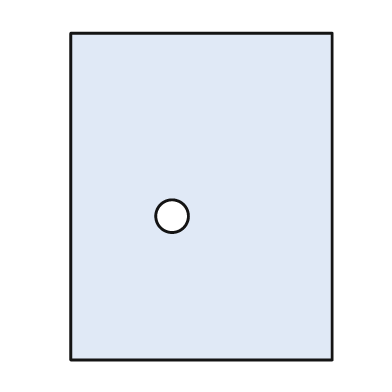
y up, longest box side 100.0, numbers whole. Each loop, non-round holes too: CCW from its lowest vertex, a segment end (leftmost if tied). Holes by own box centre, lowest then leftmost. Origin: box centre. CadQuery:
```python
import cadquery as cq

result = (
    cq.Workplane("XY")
    .moveTo(-40.0, -50.0)
    .lineTo(40.0, -50.0)
    .lineTo(40.0, 50.0)
    .lineTo(-40.0, 50.0)
    .close()
    .moveTo(-9.0, -6.0)
    .circle(5.0)
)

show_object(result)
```